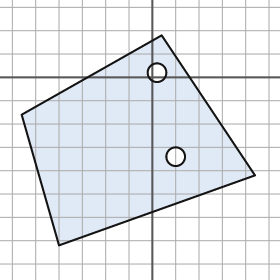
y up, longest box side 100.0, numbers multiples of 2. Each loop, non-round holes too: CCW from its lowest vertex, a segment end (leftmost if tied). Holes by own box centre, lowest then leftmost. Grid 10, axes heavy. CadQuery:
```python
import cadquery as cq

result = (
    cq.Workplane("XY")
    .moveTo(-40.0, -72.0)
    .lineTo(44.0, -42.0)
    .lineTo(4.0, 18.0)
    .lineTo(-56.0, -16.0)
    .close()
    .moveTo(10.0, -34.0)
    .circle(4.0)
    .moveTo(2.0, 2.0)
    .circle(4.0)
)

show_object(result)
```